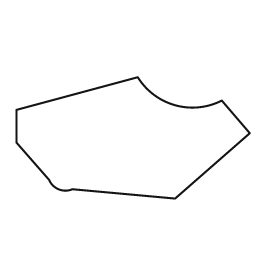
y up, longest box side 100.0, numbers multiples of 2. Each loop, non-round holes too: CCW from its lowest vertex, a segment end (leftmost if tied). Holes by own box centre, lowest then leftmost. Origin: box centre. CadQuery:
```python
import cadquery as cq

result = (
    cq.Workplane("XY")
    .moveTo(18.0, -26.0)
    .lineTo(50.0, 2.0)
    .lineTo(38.0, 16.0)
    .threePointArc((18.0, 14.0), (2.0, 26.0))
    .lineTo(-50.0, 12.0)
    .lineTo(-50.0, -2.0)
    .lineTo(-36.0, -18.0)
    .threePointArc((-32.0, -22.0), (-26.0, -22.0))
    .close()
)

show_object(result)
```